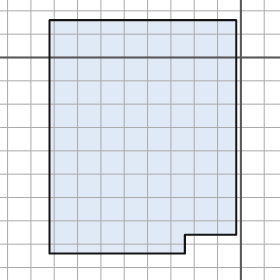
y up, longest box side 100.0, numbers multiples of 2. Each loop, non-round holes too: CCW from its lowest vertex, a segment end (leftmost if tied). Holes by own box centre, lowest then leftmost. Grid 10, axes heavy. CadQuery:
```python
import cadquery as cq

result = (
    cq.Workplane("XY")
    .moveTo(-82.0, -84.0)
    .lineTo(-24.0, -84.0)
    .lineTo(-24.0, -76.0)
    .lineTo(-2.0, -76.0)
    .lineTo(-2.0, 16.0)
    .lineTo(-82.0, 16.0)
    .close()
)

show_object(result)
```